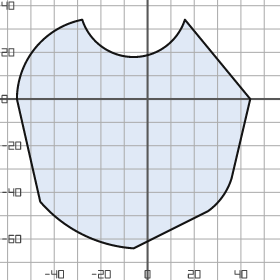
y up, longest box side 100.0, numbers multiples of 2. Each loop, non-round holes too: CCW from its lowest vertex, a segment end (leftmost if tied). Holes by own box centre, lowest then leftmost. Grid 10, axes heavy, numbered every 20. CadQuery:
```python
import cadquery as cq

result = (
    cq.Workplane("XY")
    .moveTo(-6.0, -64.0)
    .lineTo(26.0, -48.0)
    .threePointArc((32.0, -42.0), (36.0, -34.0))
    .lineTo(44.0, 0.0)
    .lineTo(16.0, 34.0)
    .threePointArc((-6.0, 18.0), (-28.0, 34.0))
    .threePointArc((-48.0, 22.0), (-56.0, 0.0))
    .lineTo(-46.0, -44.0)
    .threePointArc((-28.0, -58.0), (-6.0, -64.0))
    .close()
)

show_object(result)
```